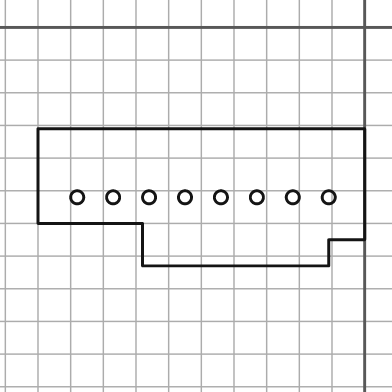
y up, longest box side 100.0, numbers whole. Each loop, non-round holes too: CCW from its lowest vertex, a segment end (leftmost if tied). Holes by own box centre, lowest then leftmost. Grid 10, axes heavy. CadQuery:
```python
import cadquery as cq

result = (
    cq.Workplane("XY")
    .moveTo(-68.0, -73.0)
    .lineTo(-11.0, -73.0)
    .lineTo(-11.0, -65.0)
    .lineTo(0.0, -65.0)
    .lineTo(0.0, -31.0)
    .lineTo(-100.0, -31.0)
    .lineTo(-100.0, -60.0)
    .lineTo(-68.0, -60.0)
    .close()
    .moveTo(-88.0, -52.0)
    .circle(2.0)
    .moveTo(-77.0, -52.0)
    .circle(2.0)
    .moveTo(-66.0, -52.0)
    .circle(2.0)
    .moveTo(-55.0, -52.0)
    .circle(2.0)
    .moveTo(-44.0, -52.0)
    .circle(2.0)
    .moveTo(-33.0, -52.0)
    .circle(2.0)
    .moveTo(-22.0, -52.0)
    .circle(2.0)
    .moveTo(-11.0, -52.0)
    .circle(2.0)
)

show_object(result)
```